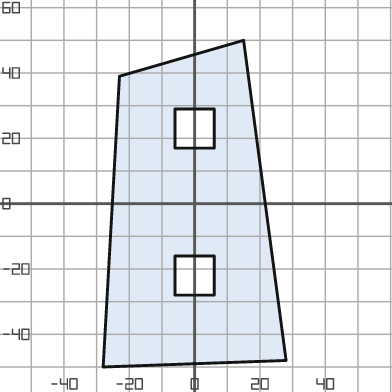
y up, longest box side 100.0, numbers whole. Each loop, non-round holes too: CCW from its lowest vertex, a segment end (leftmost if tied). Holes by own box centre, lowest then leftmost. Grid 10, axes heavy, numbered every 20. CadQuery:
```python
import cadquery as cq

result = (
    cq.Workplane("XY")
    .moveTo(-28.0, -50.0)
    .lineTo(28.0, -48.0)
    .lineTo(15.0, 50.0)
    .lineTo(-23.0, 39.0)
    .close()
    .moveTo(-6.0, -28.0)
    .lineTo(6.0, -28.0)
    .lineTo(6.0, -16.0)
    .lineTo(-6.0, -16.0)
    .close()
    .moveTo(-6.0, 17.0)
    .lineTo(6.0, 17.0)
    .lineTo(6.0, 29.0)
    .lineTo(-6.0, 29.0)
    .close()
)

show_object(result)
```